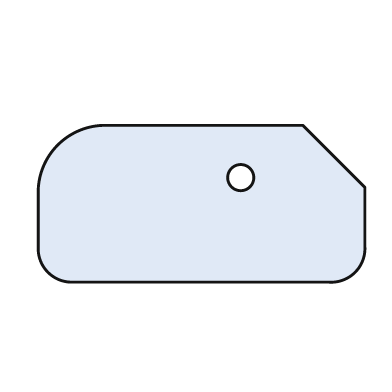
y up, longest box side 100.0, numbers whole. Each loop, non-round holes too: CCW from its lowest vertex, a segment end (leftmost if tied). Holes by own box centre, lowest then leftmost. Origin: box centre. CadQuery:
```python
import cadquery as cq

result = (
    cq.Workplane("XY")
    .moveTo(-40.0, -24.0)
    .lineTo(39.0, -24.0)
    .threePointArc((47.0, -21.0), (50.0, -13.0))
    .lineTo(50.0, 5.0)
    .lineTo(31.0, 24.0)
    .lineTo(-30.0, 24.0)
    .threePointArc((-44.0, 18.0), (-50.0, 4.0))
    .lineTo(-50.0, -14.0)
    .threePointArc((-47.0, -21.0), (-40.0, -24.0))
    .close()
    .moveTo(12.0, 8.0)
    .circle(4.0)
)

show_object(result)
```